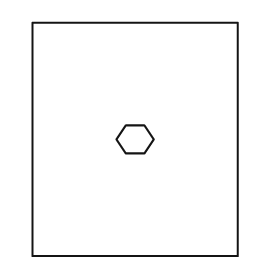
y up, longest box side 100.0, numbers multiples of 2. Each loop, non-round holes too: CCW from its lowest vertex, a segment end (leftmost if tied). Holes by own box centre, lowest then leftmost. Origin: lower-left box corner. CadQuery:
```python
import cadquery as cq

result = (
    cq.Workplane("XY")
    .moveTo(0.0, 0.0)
    .lineTo(88.0, 0.0)
    .lineTo(88.0, 100.0)
    .lineTo(0.0, 100.0)
    .close()
    .moveTo(40.0, 44.0)
    .lineTo(48.0, 44.0)
    .lineTo(52.0, 50.0)
    .lineTo(48.0, 56.0)
    .lineTo(40.0, 56.0)
    .lineTo(36.0, 50.0)
    .close()
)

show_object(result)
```